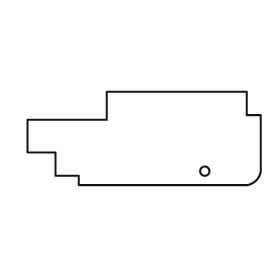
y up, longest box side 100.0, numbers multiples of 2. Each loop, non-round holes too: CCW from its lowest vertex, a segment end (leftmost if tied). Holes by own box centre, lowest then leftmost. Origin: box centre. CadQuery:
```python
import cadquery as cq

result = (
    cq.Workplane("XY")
    .moveTo(-28.0, -20.0)
    .lineTo(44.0, -20.0)
    .threePointArc((48.0, -18.0), (50.0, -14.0))
    .lineTo(50.0, 10.0)
    .lineTo(44.0, 10.0)
    .lineTo(44.0, 20.0)
    .lineTo(-16.0, 20.0)
    .lineTo(-16.0, 8.0)
    .lineTo(-50.0, 8.0)
    .lineTo(-50.0, -6.0)
    .lineTo(-38.0, -6.0)
    .lineTo(-38.0, -16.0)
    .lineTo(-28.0, -16.0)
    .close()
    .moveTo(26.0, -14.0)
    .circle(2.0)
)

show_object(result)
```